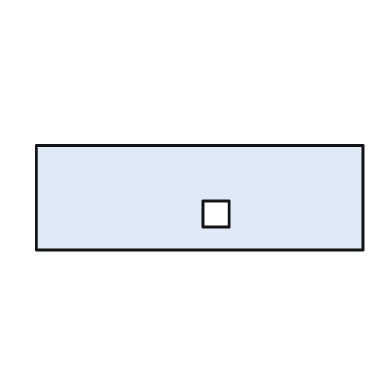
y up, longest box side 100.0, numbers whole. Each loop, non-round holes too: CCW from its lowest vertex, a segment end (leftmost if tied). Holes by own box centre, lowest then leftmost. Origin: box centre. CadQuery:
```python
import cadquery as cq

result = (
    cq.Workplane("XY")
    .moveTo(-50.0, -16.0)
    .lineTo(50.0, -16.0)
    .lineTo(50.0, 16.0)
    .lineTo(-50.0, 16.0)
    .close()
    .moveTo(1.0, -9.0)
    .lineTo(9.0, -9.0)
    .lineTo(9.0, -1.0)
    .lineTo(1.0, -1.0)
    .close()
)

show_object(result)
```